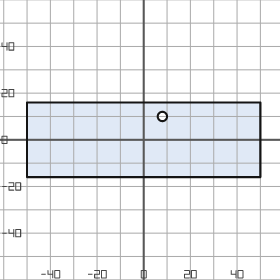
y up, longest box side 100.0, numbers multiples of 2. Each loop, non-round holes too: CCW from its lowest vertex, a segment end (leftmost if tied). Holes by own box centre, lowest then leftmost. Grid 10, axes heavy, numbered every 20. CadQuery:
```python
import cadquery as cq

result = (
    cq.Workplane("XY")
    .moveTo(-50.0, -16.0)
    .lineTo(50.0, -16.0)
    .lineTo(50.0, 16.0)
    .lineTo(-50.0, 16.0)
    .close()
    .moveTo(8.0, 10.0)
    .circle(2.0)
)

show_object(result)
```